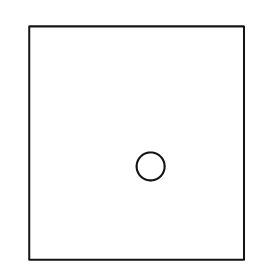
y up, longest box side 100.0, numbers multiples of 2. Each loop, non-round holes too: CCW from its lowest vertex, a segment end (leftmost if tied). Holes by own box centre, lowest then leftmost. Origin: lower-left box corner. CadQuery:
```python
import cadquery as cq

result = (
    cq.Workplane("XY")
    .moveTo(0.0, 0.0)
    .lineTo(92.0, 0.0)
    .lineTo(92.0, 100.0)
    .lineTo(0.0, 100.0)
    .close()
    .moveTo(52.0, 40.0)
    .circle(6.0)
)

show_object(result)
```